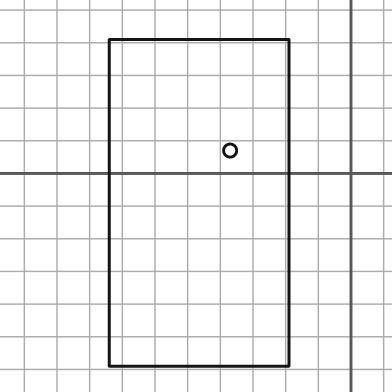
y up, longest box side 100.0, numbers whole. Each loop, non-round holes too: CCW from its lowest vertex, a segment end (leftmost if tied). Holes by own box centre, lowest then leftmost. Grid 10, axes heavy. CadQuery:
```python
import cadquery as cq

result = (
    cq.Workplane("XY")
    .moveTo(-74.0, -59.0)
    .lineTo(-19.0, -59.0)
    .lineTo(-19.0, 41.0)
    .lineTo(-74.0, 41.0)
    .close()
    .moveTo(-37.0, 7.0)
    .circle(2.0)
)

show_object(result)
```